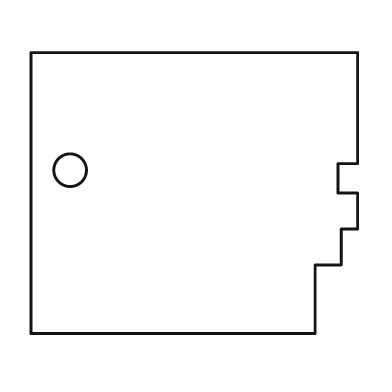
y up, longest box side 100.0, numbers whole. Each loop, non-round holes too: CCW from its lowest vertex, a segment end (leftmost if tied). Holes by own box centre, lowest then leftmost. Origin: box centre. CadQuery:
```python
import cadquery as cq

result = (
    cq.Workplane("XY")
    .moveTo(-50.0, -43.0)
    .lineTo(37.0, -43.0)
    .lineTo(37.0, -22.0)
    .lineTo(45.0, -22.0)
    .lineTo(45.0, -11.0)
    .lineTo(50.0, -11.0)
    .lineTo(50.0, 0.0)
    .lineTo(44.0, 0.0)
    .lineTo(44.0, 9.0)
    .lineTo(50.0, 9.0)
    .lineTo(50.0, 43.0)
    .lineTo(-50.0, 43.0)
    .close()
    .moveTo(-38.0, 7.0)
    .circle(5.0)
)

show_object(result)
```